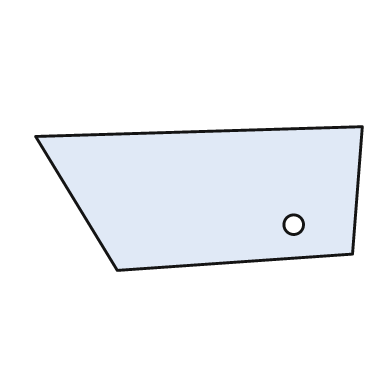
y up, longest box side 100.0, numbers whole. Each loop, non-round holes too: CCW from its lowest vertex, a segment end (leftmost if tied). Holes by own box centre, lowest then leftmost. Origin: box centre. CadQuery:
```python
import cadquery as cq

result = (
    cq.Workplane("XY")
    .moveTo(-25.0, -22.0)
    .lineTo(47.0, -17.0)
    .lineTo(50.0, 22.0)
    .lineTo(-50.0, 19.0)
    .close()
    .moveTo(29.0, -8.0)
    .circle(3.0)
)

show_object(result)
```